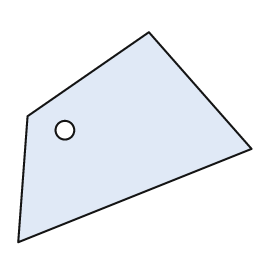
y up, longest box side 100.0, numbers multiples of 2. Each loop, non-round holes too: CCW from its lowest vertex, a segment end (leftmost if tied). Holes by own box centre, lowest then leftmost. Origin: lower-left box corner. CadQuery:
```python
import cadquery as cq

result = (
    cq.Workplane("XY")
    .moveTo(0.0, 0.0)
    .lineTo(100.0, 40.0)
    .lineTo(56.0, 90.0)
    .lineTo(4.0, 54.0)
    .close()
    .moveTo(20.0, 48.0)
    .circle(4.0)
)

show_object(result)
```